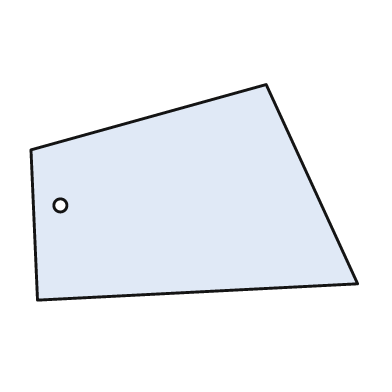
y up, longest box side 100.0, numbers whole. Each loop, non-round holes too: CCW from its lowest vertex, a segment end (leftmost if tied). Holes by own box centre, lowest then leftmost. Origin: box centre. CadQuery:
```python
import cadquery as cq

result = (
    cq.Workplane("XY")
    .moveTo(-48.0, -33.0)
    .lineTo(50.0, -28.0)
    .lineTo(22.0, 33.0)
    .lineTo(-50.0, 13.0)
    .close()
    .moveTo(-41.0, -4.0)
    .circle(2.0)
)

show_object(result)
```